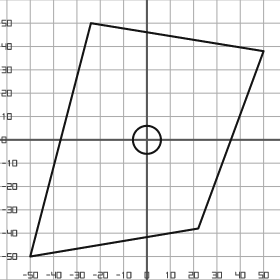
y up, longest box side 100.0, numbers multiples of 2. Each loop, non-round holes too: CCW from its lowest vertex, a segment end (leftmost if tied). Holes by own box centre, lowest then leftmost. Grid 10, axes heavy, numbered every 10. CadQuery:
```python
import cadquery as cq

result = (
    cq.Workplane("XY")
    .moveTo(-50.0, -50.0)
    .lineTo(22.0, -38.0)
    .lineTo(50.0, 38.0)
    .lineTo(-24.0, 50.0)
    .close()
    .moveTo(0.0, 0.0)
    .circle(6.0)
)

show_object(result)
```